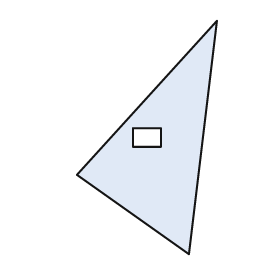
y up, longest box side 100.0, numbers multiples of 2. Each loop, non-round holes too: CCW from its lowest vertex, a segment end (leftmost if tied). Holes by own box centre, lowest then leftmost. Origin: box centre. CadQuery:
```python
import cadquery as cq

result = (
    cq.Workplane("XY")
    .moveTo(18.0, -50.0)
    .lineTo(30.0, 50.0)
    .lineTo(-30.0, -16.0)
    .close()
    .moveTo(-6.0, -4.0)
    .lineTo(6.0, -4.0)
    .lineTo(6.0, 4.0)
    .lineTo(-6.0, 4.0)
    .close()
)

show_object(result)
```